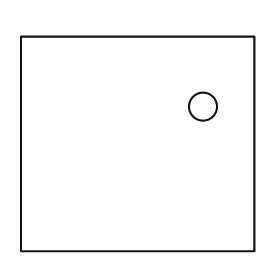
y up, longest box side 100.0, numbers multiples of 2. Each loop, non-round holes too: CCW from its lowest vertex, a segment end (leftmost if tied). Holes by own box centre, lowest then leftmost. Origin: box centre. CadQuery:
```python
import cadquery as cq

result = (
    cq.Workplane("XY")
    .moveTo(-50.0, -46.0)
    .lineTo(50.0, -46.0)
    .lineTo(50.0, 46.0)
    .lineTo(-50.0, 46.0)
    .close()
    .moveTo(28.0, 16.0)
    .circle(6.0)
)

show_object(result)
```